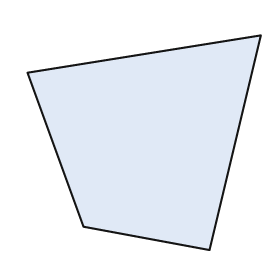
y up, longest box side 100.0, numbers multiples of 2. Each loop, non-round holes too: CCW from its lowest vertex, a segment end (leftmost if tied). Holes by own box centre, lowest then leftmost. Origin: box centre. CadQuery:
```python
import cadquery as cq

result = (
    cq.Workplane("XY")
    .moveTo(28.0, -46.0)
    .lineTo(50.0, 46.0)
    .lineTo(-50.0, 30.0)
    .lineTo(-26.0, -36.0)
    .close()
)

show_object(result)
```